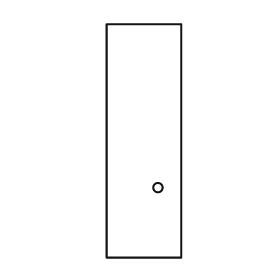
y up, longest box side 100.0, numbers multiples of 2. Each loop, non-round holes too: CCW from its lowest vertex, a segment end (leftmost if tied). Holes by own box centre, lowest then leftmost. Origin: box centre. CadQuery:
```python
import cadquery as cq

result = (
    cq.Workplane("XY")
    .moveTo(-16.0, -50.0)
    .lineTo(16.0, -50.0)
    .lineTo(16.0, 50.0)
    .lineTo(-16.0, 50.0)
    .close()
    .moveTo(6.0, -20.0)
    .circle(2.0)
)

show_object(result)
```